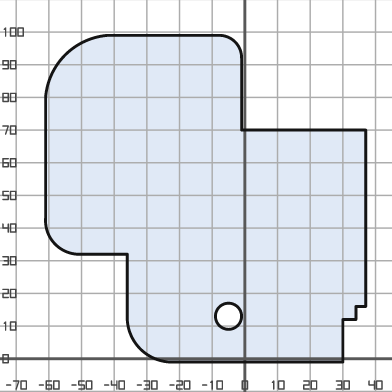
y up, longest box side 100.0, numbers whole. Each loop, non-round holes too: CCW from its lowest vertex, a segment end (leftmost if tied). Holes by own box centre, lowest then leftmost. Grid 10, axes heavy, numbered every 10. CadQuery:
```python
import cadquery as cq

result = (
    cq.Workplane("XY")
    .moveTo(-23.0, -1.0)
    .lineTo(30.0, -1.0)
    .lineTo(30.0, 12.0)
    .lineTo(34.0, 12.0)
    .lineTo(34.0, 16.0)
    .lineTo(37.0, 16.0)
    .lineTo(37.0, 70.0)
    .lineTo(-1.0, 70.0)
    .lineTo(-1.0, 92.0)
    .threePointArc((-3.0, 97.0), (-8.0, 99.0))
    .lineTo(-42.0, 99.0)
    .threePointArc((-55.0, 93.0), (-61.0, 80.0))
    .lineTo(-61.0, 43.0)
    .threePointArc((-58.0, 35.0), (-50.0, 32.0))
    .lineTo(-36.0, 32.0)
    .lineTo(-36.0, 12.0)
    .threePointArc((-32.0, 3.0), (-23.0, -1.0))
    .close()
    .moveTo(-5.0, 13.0)
    .circle(4.0)
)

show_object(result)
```